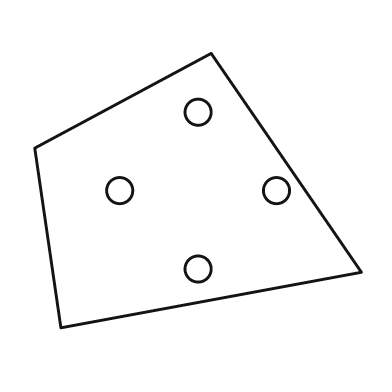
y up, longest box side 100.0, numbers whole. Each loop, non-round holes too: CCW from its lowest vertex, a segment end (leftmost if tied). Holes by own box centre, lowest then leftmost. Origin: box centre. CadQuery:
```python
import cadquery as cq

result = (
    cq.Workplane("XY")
    .moveTo(-42.0, -42.0)
    .lineTo(50.0, -25.0)
    .lineTo(4.0, 42.0)
    .lineTo(-50.0, 13.0)
    .close()
    .moveTo(0.0, -24.0)
    .circle(4.0)
    .moveTo(-24.0, 0.0)
    .circle(4.0)
    .moveTo(24.0, 0.0)
    .circle(4.0)
    .moveTo(0.0, 24.0)
    .circle(4.0)
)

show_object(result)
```